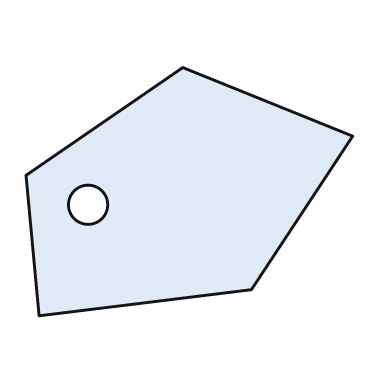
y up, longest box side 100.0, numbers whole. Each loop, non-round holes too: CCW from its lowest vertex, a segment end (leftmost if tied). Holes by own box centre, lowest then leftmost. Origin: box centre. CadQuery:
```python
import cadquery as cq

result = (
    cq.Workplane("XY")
    .moveTo(-46.0, -38.0)
    .lineTo(19.0, -30.0)
    .lineTo(50.0, 17.0)
    .lineTo(-2.0, 38.0)
    .lineTo(-50.0, 5.0)
    .close()
    .moveTo(-31.0, -4.0)
    .circle(6.0)
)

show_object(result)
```